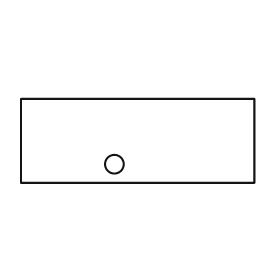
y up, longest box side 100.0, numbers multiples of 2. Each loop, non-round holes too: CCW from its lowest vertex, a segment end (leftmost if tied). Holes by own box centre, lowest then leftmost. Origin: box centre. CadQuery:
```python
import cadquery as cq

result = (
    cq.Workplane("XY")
    .moveTo(-50.0, -18.0)
    .lineTo(50.0, -18.0)
    .lineTo(50.0, 18.0)
    .lineTo(-50.0, 18.0)
    .close()
    .moveTo(-10.0, -10.0)
    .circle(4.0)
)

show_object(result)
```